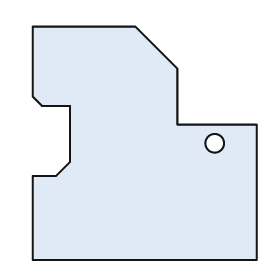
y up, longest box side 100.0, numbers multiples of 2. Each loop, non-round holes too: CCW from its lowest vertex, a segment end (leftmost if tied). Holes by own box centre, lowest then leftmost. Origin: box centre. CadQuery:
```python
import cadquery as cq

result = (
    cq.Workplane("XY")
    .moveTo(-48.0, -50.0)
    .lineTo(48.0, -50.0)
    .lineTo(48.0, 8.0)
    .lineTo(14.0, 8.0)
    .lineTo(14.0, 32.0)
    .lineTo(-4.0, 50.0)
    .lineTo(-48.0, 50.0)
    .lineTo(-48.0, 20.0)
    .lineTo(-44.0, 16.0)
    .lineTo(-32.0, 16.0)
    .lineTo(-32.0, -8.0)
    .lineTo(-38.0, -14.0)
    .lineTo(-48.0, -14.0)
    .close()
    .moveTo(30.0, 0.0)
    .circle(4.0)
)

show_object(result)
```